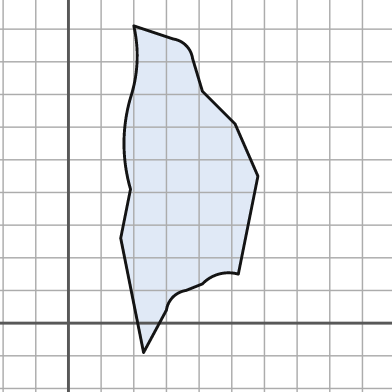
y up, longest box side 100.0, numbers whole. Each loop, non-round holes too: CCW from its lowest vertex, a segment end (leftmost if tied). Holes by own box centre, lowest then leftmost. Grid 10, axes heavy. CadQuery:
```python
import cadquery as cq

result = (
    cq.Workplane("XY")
    .moveTo(23.0, -9.0)
    .lineTo(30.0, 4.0)
    .threePointArc((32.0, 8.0), (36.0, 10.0))
    .lineTo(41.0, 12.0)
    .threePointArc((46.0, 15.0), (52.0, 15.0))
    .lineTo(58.0, 45.0)
    .lineTo(51.0, 61.0)
    .lineTo(41.0, 71.0)
    .lineTo(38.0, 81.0)
    .threePointArc((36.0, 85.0), (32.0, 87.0))
    .lineTo(20.0, 91.0)
    .threePointArc((21.0, 80.0), (19.0, 69.0))
    .threePointArc((17.0, 55.0), (19.0, 41.0))
    .lineTo(16.0, 26.0)
    .close()
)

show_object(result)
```